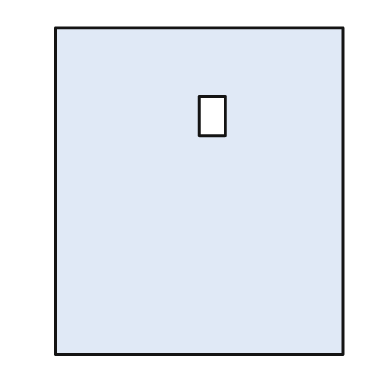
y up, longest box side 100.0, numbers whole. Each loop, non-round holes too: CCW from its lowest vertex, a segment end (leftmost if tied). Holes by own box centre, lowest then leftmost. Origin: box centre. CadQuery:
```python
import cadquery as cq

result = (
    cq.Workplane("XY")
    .moveTo(-44.0, -50.0)
    .lineTo(44.0, -50.0)
    .lineTo(44.0, 50.0)
    .lineTo(-44.0, 50.0)
    .close()
    .moveTo(0.0, 17.0)
    .lineTo(8.0, 17.0)
    .lineTo(8.0, 29.0)
    .lineTo(0.0, 29.0)
    .close()
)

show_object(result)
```